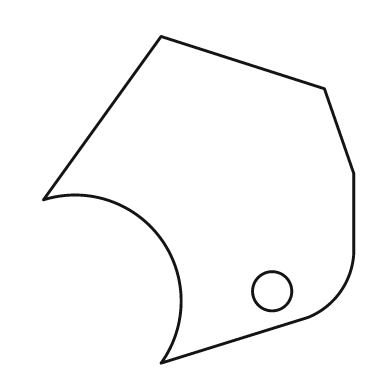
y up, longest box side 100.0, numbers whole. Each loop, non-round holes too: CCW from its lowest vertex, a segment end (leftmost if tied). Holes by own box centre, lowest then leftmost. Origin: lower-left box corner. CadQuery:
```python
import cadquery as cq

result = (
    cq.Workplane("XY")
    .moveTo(36.0, 0.0)
    .lineTo(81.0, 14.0)
    .threePointArc((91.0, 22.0), (95.0, 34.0))
    .lineTo(95.0, 58.0)
    .lineTo(86.0, 84.0)
    .lineTo(36.0, 100.0)
    .lineTo(0.0, 50.0)
    .threePointArc((36.0, 38.0), (36.0, 0.0))
    .close()
    .moveTo(70.0, 22.0)
    .circle(6.0)
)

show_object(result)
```